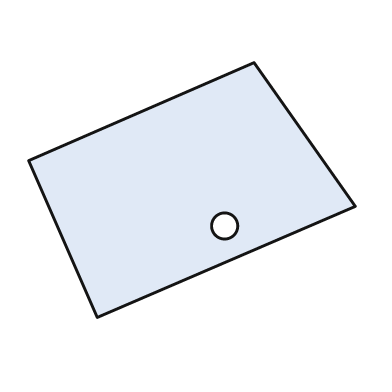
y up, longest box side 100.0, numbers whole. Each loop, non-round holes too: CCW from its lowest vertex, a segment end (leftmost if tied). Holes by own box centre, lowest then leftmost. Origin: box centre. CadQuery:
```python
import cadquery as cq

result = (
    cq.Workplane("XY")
    .moveTo(-29.0, -39.0)
    .lineTo(50.0, -5.0)
    .lineTo(19.0, 39.0)
    .lineTo(-50.0, 9.0)
    .close()
    .moveTo(10.0, -11.0)
    .circle(4.0)
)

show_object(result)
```